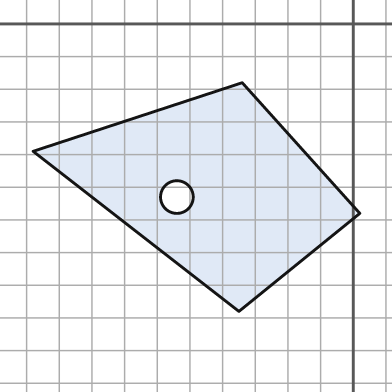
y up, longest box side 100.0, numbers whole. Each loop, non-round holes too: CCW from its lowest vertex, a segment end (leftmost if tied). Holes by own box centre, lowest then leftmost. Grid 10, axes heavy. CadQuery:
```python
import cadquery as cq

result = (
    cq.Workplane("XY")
    .moveTo(-35.0, -88.0)
    .lineTo(2.0, -58.0)
    .lineTo(-34.0, -18.0)
    .lineTo(-98.0, -39.0)
    .close()
    .moveTo(-54.0, -53.0)
    .circle(5.0)
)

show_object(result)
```